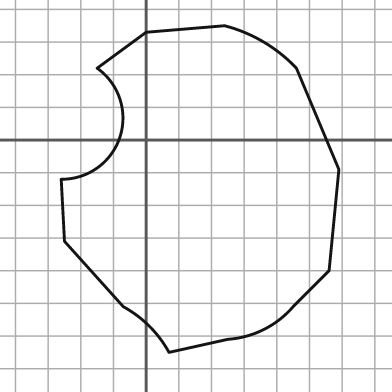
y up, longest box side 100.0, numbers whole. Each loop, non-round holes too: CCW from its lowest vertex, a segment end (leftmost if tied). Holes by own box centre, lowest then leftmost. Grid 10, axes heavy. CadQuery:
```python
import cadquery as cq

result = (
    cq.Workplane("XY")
    .moveTo(7.0, -65.0)
    .lineTo(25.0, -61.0)
    .threePointArc((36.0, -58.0), (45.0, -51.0))
    .lineTo(56.0, -40.0)
    .lineTo(59.0, -9.0)
    .lineTo(46.0, 22.0)
    .threePointArc((36.0, 30.0), (24.0, 35.0))
    .lineTo(0.0, 33.0)
    .lineTo(-15.0, 22.0)
    .threePointArc((-8.0, 1.0), (-26.0, -12.0))
    .lineTo(-25.0, -31.0)
    .lineTo(-7.0, -51.0)
    .threePointArc((1.0, -57.0), (7.0, -65.0))
    .close()
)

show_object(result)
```